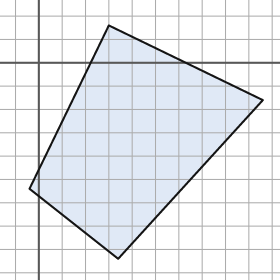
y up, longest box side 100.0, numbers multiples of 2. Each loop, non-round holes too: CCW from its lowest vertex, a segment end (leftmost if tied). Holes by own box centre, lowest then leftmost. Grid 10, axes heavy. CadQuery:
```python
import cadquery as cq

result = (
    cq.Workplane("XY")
    .moveTo(34.0, -84.0)
    .lineTo(96.0, -16.0)
    .lineTo(30.0, 16.0)
    .lineTo(-4.0, -54.0)
    .close()
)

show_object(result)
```